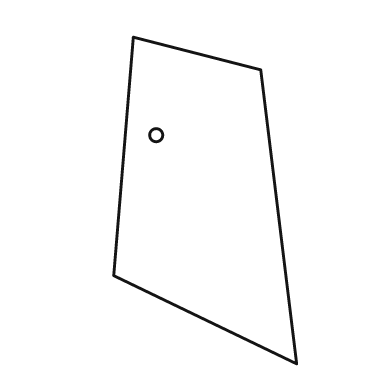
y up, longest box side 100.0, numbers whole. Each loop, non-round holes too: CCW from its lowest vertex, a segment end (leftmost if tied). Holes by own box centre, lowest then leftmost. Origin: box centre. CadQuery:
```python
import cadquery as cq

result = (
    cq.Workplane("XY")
    .moveTo(28.0, -50.0)
    .lineTo(17.0, 40.0)
    .lineTo(-22.0, 50.0)
    .lineTo(-28.0, -23.0)
    .close()
    .moveTo(-15.0, 20.0)
    .circle(2.0)
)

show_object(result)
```